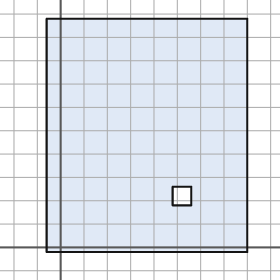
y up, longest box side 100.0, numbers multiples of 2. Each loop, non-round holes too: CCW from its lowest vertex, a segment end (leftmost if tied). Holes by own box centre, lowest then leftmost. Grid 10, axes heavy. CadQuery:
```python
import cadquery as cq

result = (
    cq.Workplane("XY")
    .moveTo(-6.0, -2.0)
    .lineTo(80.0, -2.0)
    .lineTo(80.0, 98.0)
    .lineTo(-6.0, 98.0)
    .close()
    .moveTo(48.0, 18.0)
    .lineTo(56.0, 18.0)
    .lineTo(56.0, 26.0)
    .lineTo(48.0, 26.0)
    .close()
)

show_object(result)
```